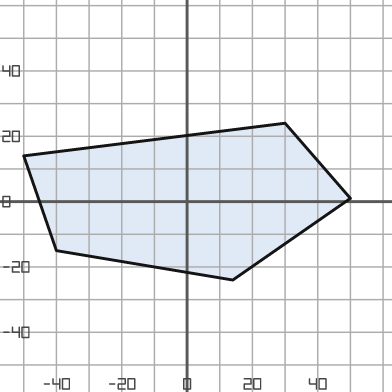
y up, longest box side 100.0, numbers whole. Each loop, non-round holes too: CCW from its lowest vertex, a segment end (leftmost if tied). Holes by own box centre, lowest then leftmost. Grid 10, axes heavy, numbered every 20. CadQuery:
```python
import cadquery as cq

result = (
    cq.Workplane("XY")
    .moveTo(14.0, -24.0)
    .lineTo(50.0, 1.0)
    .lineTo(30.0, 24.0)
    .lineTo(-50.0, 14.0)
    .lineTo(-40.0, -15.0)
    .close()
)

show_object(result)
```